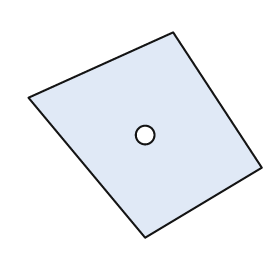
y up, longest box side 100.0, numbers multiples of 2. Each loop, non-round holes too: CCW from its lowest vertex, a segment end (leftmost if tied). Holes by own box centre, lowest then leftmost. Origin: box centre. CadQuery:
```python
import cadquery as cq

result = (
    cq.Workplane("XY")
    .moveTo(0.0, -44.0)
    .lineTo(50.0, -14.0)
    .lineTo(12.0, 44.0)
    .lineTo(-50.0, 16.0)
    .close()
    .moveTo(0.0, 0.0)
    .circle(4.0)
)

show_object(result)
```